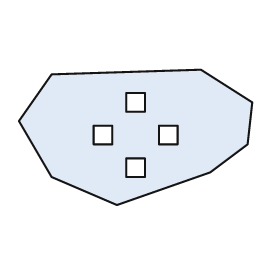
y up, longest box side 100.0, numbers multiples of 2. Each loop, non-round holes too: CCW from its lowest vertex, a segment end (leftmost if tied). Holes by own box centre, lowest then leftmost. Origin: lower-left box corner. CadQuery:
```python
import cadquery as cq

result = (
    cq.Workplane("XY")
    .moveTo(42.0, 0.0)
    .lineTo(82.0, 14.0)
    .lineTo(98.0, 26.0)
    .lineTo(100.0, 44.0)
    .lineTo(78.0, 58.0)
    .lineTo(14.0, 56.0)
    .lineTo(0.0, 36.0)
    .lineTo(14.0, 12.0)
    .close()
    .moveTo(46.0, 12.0)
    .lineTo(54.0, 12.0)
    .lineTo(54.0, 20.0)
    .lineTo(46.0, 20.0)
    .close()
    .moveTo(32.0, 26.0)
    .lineTo(40.0, 26.0)
    .lineTo(40.0, 34.0)
    .lineTo(32.0, 34.0)
    .close()
    .moveTo(60.0, 26.0)
    .lineTo(68.0, 26.0)
    .lineTo(68.0, 34.0)
    .lineTo(60.0, 34.0)
    .close()
    .moveTo(46.0, 40.0)
    .lineTo(54.0, 40.0)
    .lineTo(54.0, 48.0)
    .lineTo(46.0, 48.0)
    .close()
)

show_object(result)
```